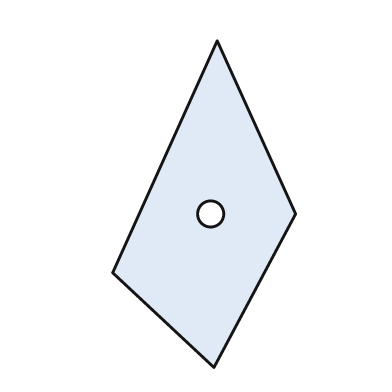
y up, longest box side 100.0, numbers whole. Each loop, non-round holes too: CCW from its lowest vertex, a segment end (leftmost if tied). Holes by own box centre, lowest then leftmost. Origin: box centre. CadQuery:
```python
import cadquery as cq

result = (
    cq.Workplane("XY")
    .moveTo(3.0, -50.0)
    .lineTo(28.0, -3.0)
    .lineTo(4.0, 50.0)
    .lineTo(-28.0, -21.0)
    .close()
    .moveTo(2.0, -3.0)
    .circle(4.0)
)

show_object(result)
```